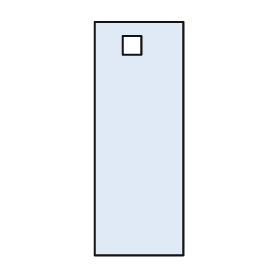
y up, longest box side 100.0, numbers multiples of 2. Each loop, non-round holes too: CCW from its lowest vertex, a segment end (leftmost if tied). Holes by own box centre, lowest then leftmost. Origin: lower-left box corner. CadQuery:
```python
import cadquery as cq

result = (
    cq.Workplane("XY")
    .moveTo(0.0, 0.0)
    .lineTo(38.0, 0.0)
    .lineTo(38.0, 100.0)
    .lineTo(0.0, 100.0)
    .close()
    .moveTo(12.0, 86.0)
    .lineTo(20.0, 86.0)
    .lineTo(20.0, 94.0)
    .lineTo(12.0, 94.0)
    .close()
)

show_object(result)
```